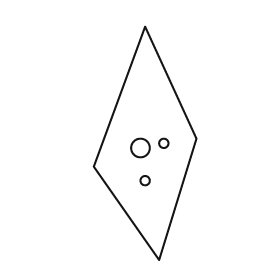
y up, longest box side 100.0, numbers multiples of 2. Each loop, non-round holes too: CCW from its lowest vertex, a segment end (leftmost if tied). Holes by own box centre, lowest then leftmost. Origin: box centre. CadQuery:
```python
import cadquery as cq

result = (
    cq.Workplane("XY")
    .moveTo(6.0, -50.0)
    .lineTo(22.0, 2.0)
    .lineTo(0.0, 50.0)
    .lineTo(-22.0, -10.0)
    .close()
    .moveTo(0.0, -16.0)
    .circle(2.0)
    .moveTo(-2.0, -2.0)
    .circle(4.0)
    .moveTo(8.0, 0.0)
    .circle(2.0)
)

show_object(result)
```